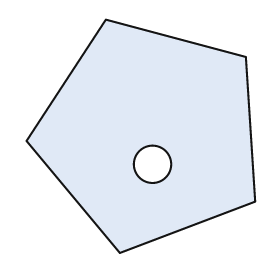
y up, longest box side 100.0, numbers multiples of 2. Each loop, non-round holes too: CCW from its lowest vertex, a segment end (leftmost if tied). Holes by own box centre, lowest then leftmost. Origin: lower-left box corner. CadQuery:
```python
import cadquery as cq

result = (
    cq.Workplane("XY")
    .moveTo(40.0, 0.0)
    .lineTo(98.0, 22.0)
    .lineTo(94.0, 84.0)
    .lineTo(34.0, 100.0)
    .lineTo(0.0, 48.0)
    .close()
    .moveTo(54.0, 38.0)
    .circle(8.0)
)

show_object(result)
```